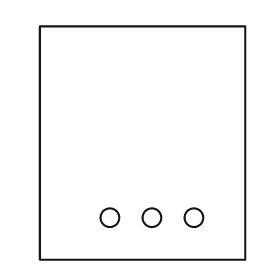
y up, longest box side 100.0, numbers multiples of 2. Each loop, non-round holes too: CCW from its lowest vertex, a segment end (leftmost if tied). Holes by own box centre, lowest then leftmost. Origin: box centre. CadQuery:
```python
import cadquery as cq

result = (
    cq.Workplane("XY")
    .moveTo(-44.0, -50.0)
    .lineTo(44.0, -50.0)
    .lineTo(44.0, 50.0)
    .lineTo(-44.0, 50.0)
    .close()
    .moveTo(-14.0, -32.0)
    .circle(4.0)
    .moveTo(4.0, -32.0)
    .circle(4.0)
    .moveTo(22.0, -32.0)
    .circle(4.0)
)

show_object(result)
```